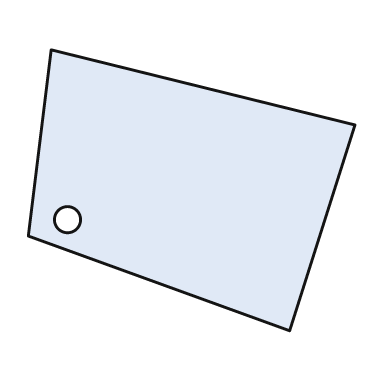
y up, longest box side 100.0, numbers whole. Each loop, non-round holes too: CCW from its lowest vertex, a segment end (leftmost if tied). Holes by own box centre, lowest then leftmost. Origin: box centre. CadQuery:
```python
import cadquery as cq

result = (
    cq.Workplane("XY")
    .moveTo(30.0, -43.0)
    .lineTo(50.0, 20.0)
    .lineTo(-43.0, 43.0)
    .lineTo(-50.0, -14.0)
    .close()
    .moveTo(-38.0, -9.0)
    .circle(4.0)
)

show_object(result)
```